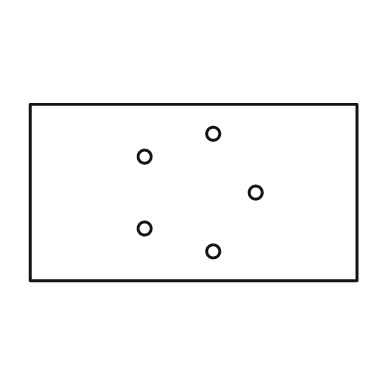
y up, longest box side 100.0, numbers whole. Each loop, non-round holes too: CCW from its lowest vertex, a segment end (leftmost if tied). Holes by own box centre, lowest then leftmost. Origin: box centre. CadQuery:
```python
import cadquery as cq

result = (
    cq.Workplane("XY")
    .moveTo(-50.0, -27.0)
    .lineTo(50.0, -27.0)
    .lineTo(50.0, 27.0)
    .lineTo(-50.0, 27.0)
    .close()
    .moveTo(6.0, -18.0)
    .circle(2.0)
    .moveTo(-15.0, -11.0)
    .circle(2.0)
    .moveTo(19.0, 0.0)
    .circle(2.0)
    .moveTo(-15.0, 11.0)
    .circle(2.0)
    .moveTo(6.0, 18.0)
    .circle(2.0)
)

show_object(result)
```